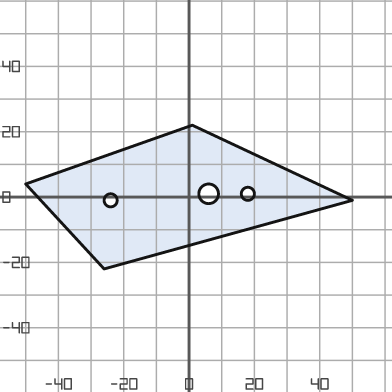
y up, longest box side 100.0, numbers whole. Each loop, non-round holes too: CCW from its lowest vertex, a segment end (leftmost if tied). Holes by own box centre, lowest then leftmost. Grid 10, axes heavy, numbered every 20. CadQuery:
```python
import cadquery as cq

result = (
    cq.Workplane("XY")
    .moveTo(-26.0, -22.0)
    .lineTo(50.0, -1.0)
    .lineTo(1.0, 22.0)
    .lineTo(-50.0, 4.0)
    .close()
    .moveTo(-24.0, -1.0)
    .circle(2.0)
    .moveTo(6.0, 1.0)
    .circle(3.0)
    .moveTo(18.0, 1.0)
    .circle(2.0)
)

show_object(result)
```